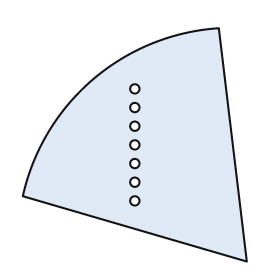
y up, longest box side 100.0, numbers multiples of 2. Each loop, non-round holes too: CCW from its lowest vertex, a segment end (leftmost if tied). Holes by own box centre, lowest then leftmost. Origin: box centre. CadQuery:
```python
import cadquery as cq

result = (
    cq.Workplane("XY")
    .moveTo(48.0, -50.0)
    .lineTo(36.0, 50.0)
    .threePointArc((-18.0, 28.0), (-48.0, -22.0))
    .close()
    .moveTo(0.0, -24.0)
    .circle(2.0)
    .moveTo(0.0, -16.0)
    .circle(2.0)
    .moveTo(0.0, -8.0)
    .circle(2.0)
    .moveTo(0.0, 0.0)
    .circle(2.0)
    .moveTo(0.0, 8.0)
    .circle(2.0)
    .moveTo(0.0, 16.0)
    .circle(2.0)
    .moveTo(0.0, 24.0)
    .circle(2.0)
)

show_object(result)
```